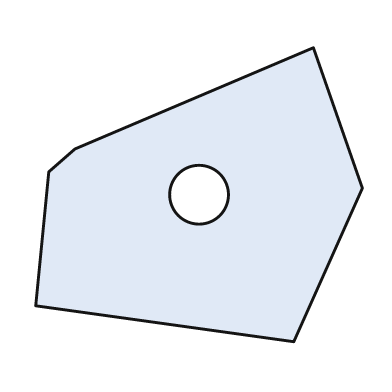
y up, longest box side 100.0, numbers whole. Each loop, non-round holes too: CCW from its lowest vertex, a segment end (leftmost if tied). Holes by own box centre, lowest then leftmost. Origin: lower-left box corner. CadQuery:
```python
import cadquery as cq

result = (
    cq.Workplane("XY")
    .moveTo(79.0, 0.0)
    .lineTo(100.0, 47.0)
    .lineTo(85.0, 90.0)
    .lineTo(12.0, 59.0)
    .lineTo(4.0, 52.0)
    .lineTo(0.0, 11.0)
    .close()
    .moveTo(50.0, 45.0)
    .circle(9.0)
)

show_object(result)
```